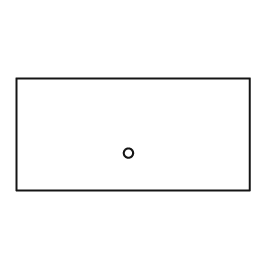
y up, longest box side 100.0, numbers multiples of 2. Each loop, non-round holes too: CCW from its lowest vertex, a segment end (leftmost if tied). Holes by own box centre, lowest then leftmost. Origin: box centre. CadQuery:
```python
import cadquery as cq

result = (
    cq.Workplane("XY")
    .moveTo(-50.0, -24.0)
    .lineTo(50.0, -24.0)
    .lineTo(50.0, 24.0)
    .lineTo(-50.0, 24.0)
    .close()
    .moveTo(-2.0, -8.0)
    .circle(2.0)
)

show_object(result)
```